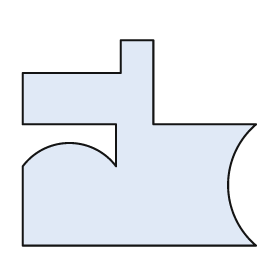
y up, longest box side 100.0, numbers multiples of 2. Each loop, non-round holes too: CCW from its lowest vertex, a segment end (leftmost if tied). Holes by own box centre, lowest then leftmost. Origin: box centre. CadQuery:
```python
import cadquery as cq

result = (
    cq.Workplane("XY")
    .moveTo(-50.0, -44.0)
    .lineTo(50.0, -44.0)
    .threePointArc((38.0, -18.0), (50.0, 8.0))
    .lineTo(6.0, 8.0)
    .lineTo(6.0, 44.0)
    .lineTo(-8.0, 44.0)
    .lineTo(-8.0, 30.0)
    .lineTo(-50.0, 30.0)
    .lineTo(-50.0, 8.0)
    .lineTo(-10.0, 8.0)
    .lineTo(-10.0, -10.0)
    .threePointArc((-30.0, 0.0), (-50.0, -10.0))
    .close()
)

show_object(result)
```